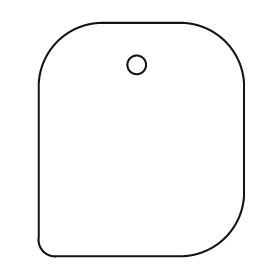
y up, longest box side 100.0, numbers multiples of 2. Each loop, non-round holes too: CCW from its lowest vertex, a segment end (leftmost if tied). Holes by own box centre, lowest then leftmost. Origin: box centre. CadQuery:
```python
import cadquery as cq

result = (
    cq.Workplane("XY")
    .moveTo(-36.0, -50.0)
    .lineTo(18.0, -50.0)
    .threePointArc((36.0, -42.0), (44.0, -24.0))
    .lineTo(44.0, 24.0)
    .threePointArc((36.0, 42.0), (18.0, 50.0))
    .lineTo(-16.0, 50.0)
    .threePointArc((-36.0, 42.0), (-44.0, 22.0))
    .lineTo(-44.0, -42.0)
    .threePointArc((-42.0, -48.0), (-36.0, -50.0))
    .close()
    .moveTo(-2.0, 32.0)
    .circle(4.0)
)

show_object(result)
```